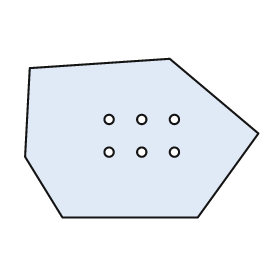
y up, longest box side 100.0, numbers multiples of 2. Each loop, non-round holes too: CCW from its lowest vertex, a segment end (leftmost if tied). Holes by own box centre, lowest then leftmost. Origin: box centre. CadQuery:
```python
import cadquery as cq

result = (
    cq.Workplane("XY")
    .moveTo(-34.0, -34.0)
    .lineTo(24.0, -34.0)
    .lineTo(50.0, 2.0)
    .lineTo(12.0, 34.0)
    .lineTo(-48.0, 30.0)
    .lineTo(-50.0, -8.0)
    .close()
    .moveTo(-14.0, -6.0)
    .circle(2.0)
    .moveTo(0.0, -6.0)
    .circle(2.0)
    .moveTo(14.0, -6.0)
    .circle(2.0)
    .moveTo(-14.0, 8.0)
    .circle(2.0)
    .moveTo(0.0, 8.0)
    .circle(2.0)
    .moveTo(14.0, 8.0)
    .circle(2.0)
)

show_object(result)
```